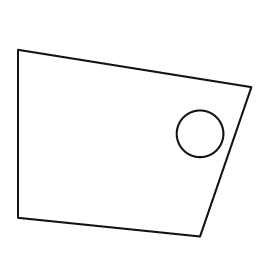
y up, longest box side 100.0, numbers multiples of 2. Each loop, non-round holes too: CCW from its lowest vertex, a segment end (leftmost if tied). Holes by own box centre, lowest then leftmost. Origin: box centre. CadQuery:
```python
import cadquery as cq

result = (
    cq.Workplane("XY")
    .moveTo(28.0, -40.0)
    .lineTo(50.0, 24.0)
    .lineTo(-50.0, 40.0)
    .lineTo(-50.0, -32.0)
    .close()
    .moveTo(28.0, 4.0)
    .circle(10.0)
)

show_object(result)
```